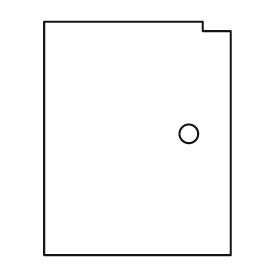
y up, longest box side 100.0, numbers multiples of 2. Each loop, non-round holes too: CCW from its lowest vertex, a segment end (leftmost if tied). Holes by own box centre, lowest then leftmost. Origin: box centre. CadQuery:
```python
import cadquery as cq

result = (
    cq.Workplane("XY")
    .moveTo(-40.0, -50.0)
    .lineTo(40.0, -50.0)
    .lineTo(40.0, 46.0)
    .lineTo(28.0, 46.0)
    .lineTo(28.0, 50.0)
    .lineTo(-40.0, 50.0)
    .close()
    .moveTo(22.0, 2.0)
    .circle(4.0)
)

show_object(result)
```